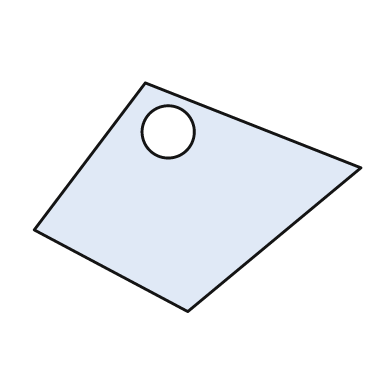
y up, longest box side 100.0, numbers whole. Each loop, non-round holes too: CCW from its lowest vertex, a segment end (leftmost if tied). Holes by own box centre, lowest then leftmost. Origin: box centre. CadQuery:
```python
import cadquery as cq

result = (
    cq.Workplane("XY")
    .moveTo(-3.0, -35.0)
    .lineTo(50.0, 9.0)
    .lineTo(-16.0, 35.0)
    .lineTo(-50.0, -10.0)
    .close()
    .moveTo(-9.0, 20.0)
    .circle(8.0)
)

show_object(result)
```